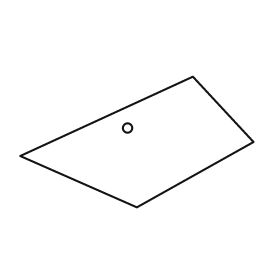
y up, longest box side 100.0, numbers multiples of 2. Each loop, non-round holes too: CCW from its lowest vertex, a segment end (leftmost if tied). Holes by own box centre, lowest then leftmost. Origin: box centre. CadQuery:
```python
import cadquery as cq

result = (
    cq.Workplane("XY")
    .moveTo(0.0, -28.0)
    .lineTo(50.0, 0.0)
    .lineTo(24.0, 28.0)
    .lineTo(-50.0, -6.0)
    .close()
    .moveTo(-4.0, 6.0)
    .circle(2.0)
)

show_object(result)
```